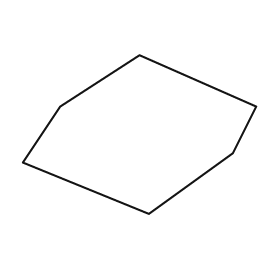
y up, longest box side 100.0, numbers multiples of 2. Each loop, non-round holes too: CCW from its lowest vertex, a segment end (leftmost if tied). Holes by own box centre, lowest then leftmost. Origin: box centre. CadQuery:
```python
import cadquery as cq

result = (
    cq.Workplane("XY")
    .moveTo(4.0, -34.0)
    .lineTo(40.0, -8.0)
    .lineTo(50.0, 12.0)
    .lineTo(0.0, 34.0)
    .lineTo(-34.0, 12.0)
    .lineTo(-50.0, -12.0)
    .close()
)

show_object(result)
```